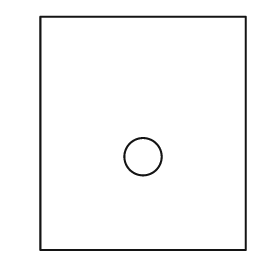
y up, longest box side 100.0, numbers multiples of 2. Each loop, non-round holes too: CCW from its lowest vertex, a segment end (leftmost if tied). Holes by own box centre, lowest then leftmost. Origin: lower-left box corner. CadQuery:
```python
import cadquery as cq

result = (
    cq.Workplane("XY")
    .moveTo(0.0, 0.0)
    .lineTo(88.0, 0.0)
    .lineTo(88.0, 100.0)
    .lineTo(0.0, 100.0)
    .close()
    .moveTo(44.0, 40.0)
    .circle(8.0)
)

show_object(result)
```